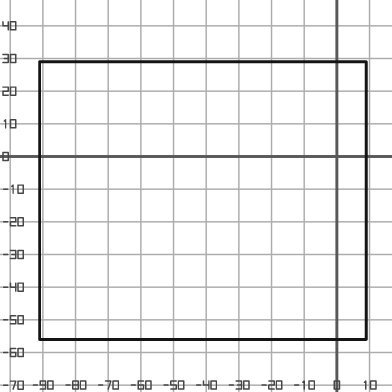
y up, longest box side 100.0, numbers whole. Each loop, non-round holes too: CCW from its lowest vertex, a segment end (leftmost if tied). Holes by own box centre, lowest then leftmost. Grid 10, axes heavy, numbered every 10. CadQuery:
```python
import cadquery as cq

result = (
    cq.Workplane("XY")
    .moveTo(-91.0, -56.0)
    .lineTo(9.0, -56.0)
    .lineTo(9.0, 29.0)
    .lineTo(-91.0, 29.0)
    .close()
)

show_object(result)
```